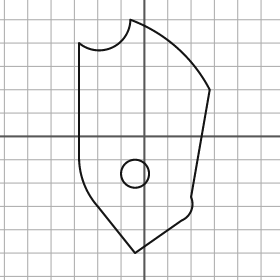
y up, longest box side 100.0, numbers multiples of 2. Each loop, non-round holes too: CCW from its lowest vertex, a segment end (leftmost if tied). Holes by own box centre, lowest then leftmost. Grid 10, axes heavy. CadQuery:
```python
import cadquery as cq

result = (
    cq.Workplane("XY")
    .moveTo(-4.0, -50.0)
    .lineTo(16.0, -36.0)
    .threePointArc((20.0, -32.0), (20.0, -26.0))
    .lineTo(28.0, 20.0)
    .threePointArc((14.0, 38.0), (-6.0, 50.0))
    .threePointArc((-14.0, 38.0), (-28.0, 40.0))
    .lineTo(-28.0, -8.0)
    .threePointArc((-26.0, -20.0), (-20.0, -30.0))
    .close()
    .moveTo(-4.0, -16.0)
    .circle(6.0)
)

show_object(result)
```